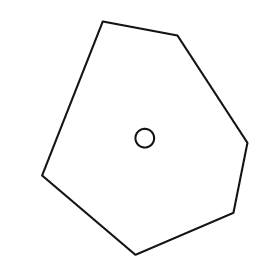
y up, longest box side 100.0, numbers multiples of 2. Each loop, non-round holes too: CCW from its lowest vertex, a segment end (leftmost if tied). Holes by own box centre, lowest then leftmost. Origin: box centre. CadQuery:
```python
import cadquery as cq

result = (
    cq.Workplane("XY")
    .moveTo(-4.0, -50.0)
    .lineTo(38.0, -32.0)
    .lineTo(44.0, -2.0)
    .lineTo(14.0, 44.0)
    .lineTo(-18.0, 50.0)
    .lineTo(-44.0, -16.0)
    .close()
    .moveTo(0.0, 0.0)
    .circle(4.0)
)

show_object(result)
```